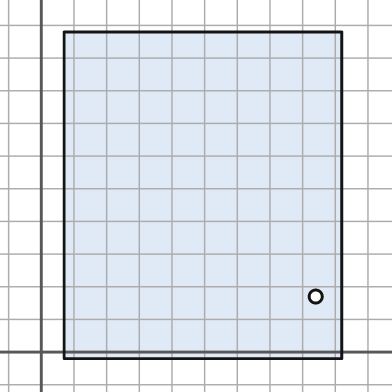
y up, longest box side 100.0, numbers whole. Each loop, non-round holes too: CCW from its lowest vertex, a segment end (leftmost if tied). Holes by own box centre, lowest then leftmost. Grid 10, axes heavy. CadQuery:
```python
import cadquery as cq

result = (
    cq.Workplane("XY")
    .moveTo(7.0, -2.0)
    .lineTo(92.0, -2.0)
    .lineTo(92.0, 98.0)
    .lineTo(7.0, 98.0)
    .close()
    .moveTo(84.0, 17.0)
    .circle(2.0)
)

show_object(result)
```